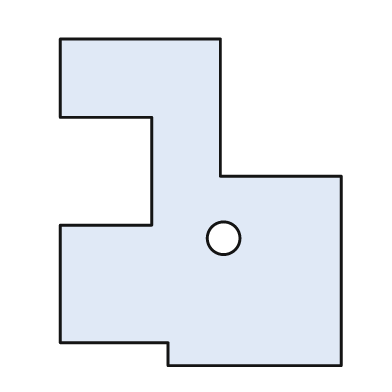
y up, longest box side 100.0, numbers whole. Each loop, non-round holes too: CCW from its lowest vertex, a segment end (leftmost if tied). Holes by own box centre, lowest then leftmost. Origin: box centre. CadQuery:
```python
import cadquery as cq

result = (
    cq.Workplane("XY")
    .moveTo(-10.0, -50.0)
    .lineTo(43.0, -50.0)
    .lineTo(43.0, 8.0)
    .lineTo(6.0, 8.0)
    .lineTo(6.0, 50.0)
    .lineTo(-43.0, 50.0)
    .lineTo(-43.0, 26.0)
    .lineTo(-15.0, 26.0)
    .lineTo(-15.0, -7.0)
    .lineTo(-43.0, -7.0)
    .lineTo(-43.0, -43.0)
    .lineTo(-10.0, -43.0)
    .close()
    .moveTo(7.0, -11.0)
    .circle(5.0)
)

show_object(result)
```